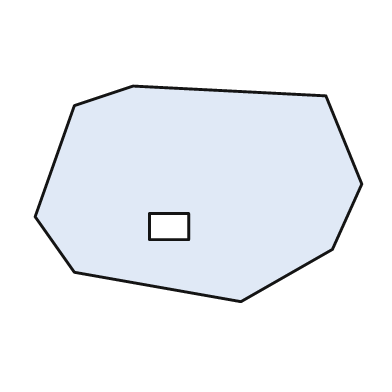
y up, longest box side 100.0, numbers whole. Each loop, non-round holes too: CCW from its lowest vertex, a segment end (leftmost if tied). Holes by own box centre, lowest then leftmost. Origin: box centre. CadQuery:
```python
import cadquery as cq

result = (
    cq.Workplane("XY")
    .moveTo(13.0, -33.0)
    .lineTo(41.0, -17.0)
    .lineTo(50.0, 3.0)
    .lineTo(39.0, 30.0)
    .lineTo(-20.0, 33.0)
    .lineTo(-38.0, 27.0)
    .lineTo(-50.0, -7.0)
    .lineTo(-38.0, -24.0)
    .close()
    .moveTo(-15.0, -14.0)
    .lineTo(-3.0, -14.0)
    .lineTo(-3.0, -6.0)
    .lineTo(-15.0, -6.0)
    .close()
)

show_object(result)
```